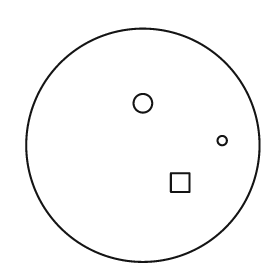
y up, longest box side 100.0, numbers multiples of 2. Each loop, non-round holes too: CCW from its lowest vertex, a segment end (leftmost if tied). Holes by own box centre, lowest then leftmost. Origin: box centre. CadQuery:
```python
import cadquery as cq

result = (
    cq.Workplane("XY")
    .moveTo(0.0, 0.0)
    .circle(50.0)
    .moveTo(12.0, -20.0)
    .lineTo(20.0, -20.0)
    .lineTo(20.0, -12.0)
    .lineTo(12.0, -12.0)
    .close()
    .moveTo(34.0, 2.0)
    .circle(2.0)
    .moveTo(0.0, 18.0)
    .circle(4.0)
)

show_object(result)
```